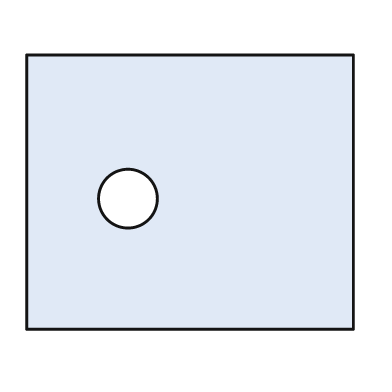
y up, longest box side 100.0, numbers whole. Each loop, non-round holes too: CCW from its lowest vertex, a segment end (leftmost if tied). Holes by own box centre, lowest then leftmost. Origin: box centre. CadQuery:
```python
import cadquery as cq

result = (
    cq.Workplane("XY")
    .moveTo(-50.0, -42.0)
    .lineTo(50.0, -42.0)
    .lineTo(50.0, 42.0)
    .lineTo(-50.0, 42.0)
    .close()
    .moveTo(-19.0, -2.0)
    .circle(9.0)
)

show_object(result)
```